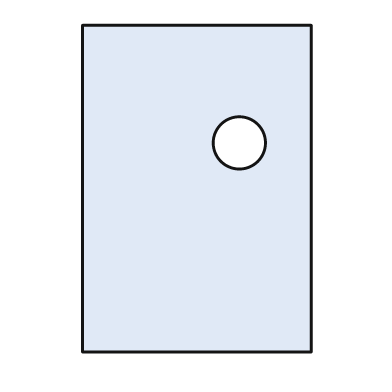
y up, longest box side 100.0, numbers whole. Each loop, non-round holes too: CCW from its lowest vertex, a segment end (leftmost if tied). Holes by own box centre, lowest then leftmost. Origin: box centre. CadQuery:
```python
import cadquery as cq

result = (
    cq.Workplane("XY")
    .moveTo(-35.0, -50.0)
    .lineTo(35.0, -50.0)
    .lineTo(35.0, 50.0)
    .lineTo(-35.0, 50.0)
    .close()
    .moveTo(13.0, 14.0)
    .circle(8.0)
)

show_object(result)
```